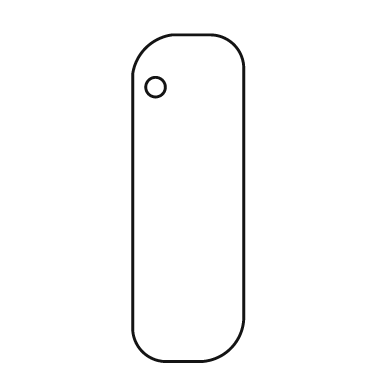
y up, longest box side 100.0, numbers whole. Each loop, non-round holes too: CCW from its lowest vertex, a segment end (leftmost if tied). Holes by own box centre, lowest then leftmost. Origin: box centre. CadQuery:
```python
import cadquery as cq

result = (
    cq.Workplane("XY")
    .moveTo(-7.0, -50.0)
    .lineTo(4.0, -50.0)
    .threePointArc((13.0, -46.0), (17.0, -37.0))
    .lineTo(17.0, 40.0)
    .threePointArc((14.0, 47.0), (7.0, 50.0))
    .lineTo(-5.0, 50.0)
    .threePointArc((-13.0, 46.0), (-17.0, 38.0))
    .lineTo(-17.0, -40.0)
    .threePointArc((-14.0, -47.0), (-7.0, -50.0))
    .close()
    .moveTo(-10.0, 34.0)
    .circle(3.0)
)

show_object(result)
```